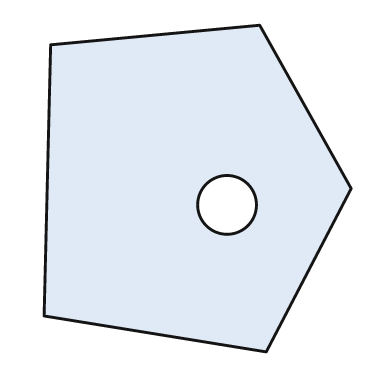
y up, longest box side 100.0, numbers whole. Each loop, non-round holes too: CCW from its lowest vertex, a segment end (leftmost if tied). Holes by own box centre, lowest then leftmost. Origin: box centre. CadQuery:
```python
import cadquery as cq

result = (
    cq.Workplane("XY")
    .moveTo(21.0, -50.0)
    .lineTo(47.0, 0.0)
    .lineTo(19.0, 50.0)
    .lineTo(-45.0, 44.0)
    .lineTo(-47.0, -39.0)
    .close()
    .moveTo(9.0, -5.0)
    .circle(9.0)
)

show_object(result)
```